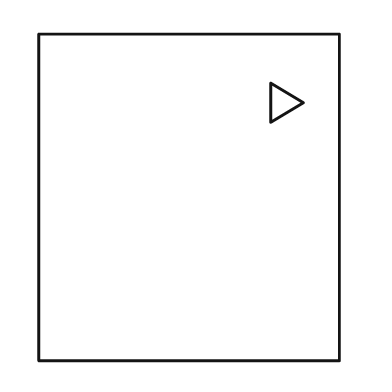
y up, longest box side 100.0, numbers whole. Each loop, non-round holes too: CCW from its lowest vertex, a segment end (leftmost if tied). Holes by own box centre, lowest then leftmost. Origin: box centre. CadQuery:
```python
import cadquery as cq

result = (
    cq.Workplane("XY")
    .moveTo(-46.0, -50.0)
    .lineTo(46.0, -50.0)
    .lineTo(46.0, 50.0)
    .lineTo(-46.0, 50.0)
    .close()
    .moveTo(25.0, 23.0)
    .lineTo(35.0, 29.0)
    .lineTo(25.0, 35.0)
    .close()
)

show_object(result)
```